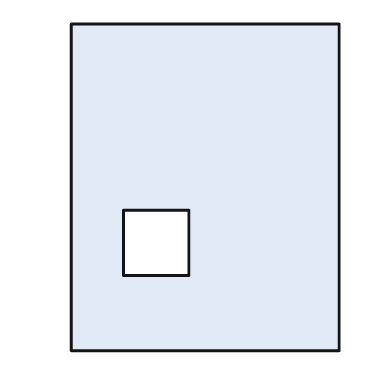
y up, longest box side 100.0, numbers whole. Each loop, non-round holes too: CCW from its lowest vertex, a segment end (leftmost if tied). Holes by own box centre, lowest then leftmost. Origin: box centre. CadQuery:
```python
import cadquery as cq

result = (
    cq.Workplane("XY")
    .moveTo(-41.0, -50.0)
    .lineTo(41.0, -50.0)
    .lineTo(41.0, 50.0)
    .lineTo(-41.0, 50.0)
    .close()
    .moveTo(-25.0, -27.0)
    .lineTo(-5.0, -27.0)
    .lineTo(-5.0, -7.0)
    .lineTo(-25.0, -7.0)
    .close()
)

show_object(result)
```